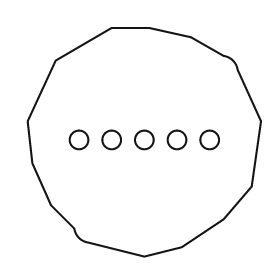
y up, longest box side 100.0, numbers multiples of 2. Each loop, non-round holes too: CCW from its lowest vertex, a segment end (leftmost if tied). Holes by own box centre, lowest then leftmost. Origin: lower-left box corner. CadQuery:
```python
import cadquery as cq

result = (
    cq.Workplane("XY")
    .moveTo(50.0, 0.0)
    .lineTo(66.0, 4.0)
    .lineTo(84.0, 16.0)
    .lineTo(96.0, 30.0)
    .lineTo(100.0, 58.0)
    .lineTo(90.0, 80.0)
    .threePointArc((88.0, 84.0), (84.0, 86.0))
    .lineTo(70.0, 94.0)
    .lineTo(52.0, 98.0)
    .lineTo(36.0, 98.0)
    .lineTo(12.0, 84.0)
    .lineTo(0.0, 58.0)
    .lineTo(2.0, 40.0)
    .lineTo(10.0, 22.0)
    .lineTo(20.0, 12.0)
    .threePointArc((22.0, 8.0), (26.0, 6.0))
    .close()
    .moveTo(22.0, 50.0)
    .circle(4.0)
    .moveTo(36.0, 50.0)
    .circle(4.0)
    .moveTo(50.0, 50.0)
    .circle(4.0)
    .moveTo(64.0, 50.0)
    .circle(4.0)
    .moveTo(78.0, 50.0)
    .circle(4.0)
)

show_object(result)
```